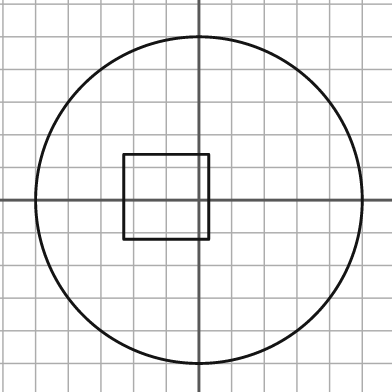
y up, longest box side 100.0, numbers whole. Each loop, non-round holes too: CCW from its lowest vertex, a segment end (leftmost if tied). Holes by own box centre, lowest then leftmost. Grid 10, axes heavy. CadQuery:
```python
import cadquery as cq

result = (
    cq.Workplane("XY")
    .moveTo(0.0, 0.0)
    .circle(50.0)
    .moveTo(-23.0, -12.0)
    .lineTo(3.0, -12.0)
    .lineTo(3.0, 14.0)
    .lineTo(-23.0, 14.0)
    .close()
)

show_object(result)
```